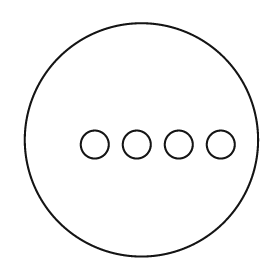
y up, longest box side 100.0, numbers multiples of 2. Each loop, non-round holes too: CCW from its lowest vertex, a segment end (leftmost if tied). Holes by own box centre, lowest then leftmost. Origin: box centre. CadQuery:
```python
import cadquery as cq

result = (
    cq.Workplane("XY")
    .moveTo(0.0, 0.0)
    .circle(50.0)
    .moveTo(-20.0, -2.0)
    .circle(6.0)
    .moveTo(-2.0, -2.0)
    .circle(6.0)
    .moveTo(16.0, -2.0)
    .circle(6.0)
    .moveTo(34.0, -2.0)
    .circle(6.0)
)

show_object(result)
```